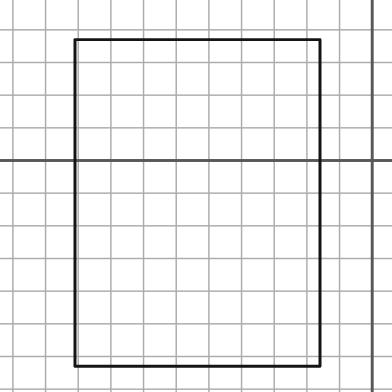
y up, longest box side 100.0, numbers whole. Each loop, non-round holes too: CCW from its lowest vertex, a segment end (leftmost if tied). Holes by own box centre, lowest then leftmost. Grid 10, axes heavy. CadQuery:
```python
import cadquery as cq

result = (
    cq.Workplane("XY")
    .moveTo(-91.0, -63.0)
    .lineTo(-16.0, -63.0)
    .lineTo(-16.0, 37.0)
    .lineTo(-91.0, 37.0)
    .close()
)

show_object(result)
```